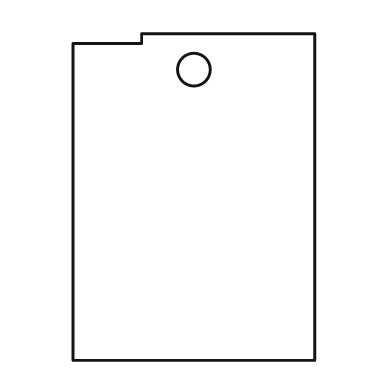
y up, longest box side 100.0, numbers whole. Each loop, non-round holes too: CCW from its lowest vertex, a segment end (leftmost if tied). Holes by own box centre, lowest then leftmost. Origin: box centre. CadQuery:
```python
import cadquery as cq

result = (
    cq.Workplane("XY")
    .moveTo(-37.0, -50.0)
    .lineTo(37.0, -50.0)
    .lineTo(37.0, 50.0)
    .lineTo(-16.0, 50.0)
    .lineTo(-16.0, 47.0)
    .lineTo(-37.0, 47.0)
    .close()
    .moveTo(0.0, 39.0)
    .circle(5.0)
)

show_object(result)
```